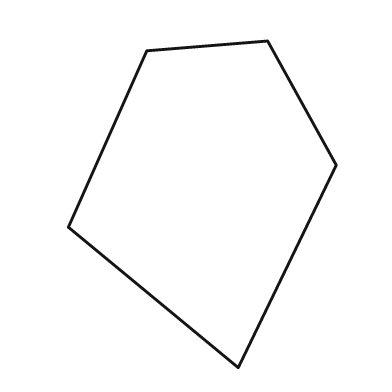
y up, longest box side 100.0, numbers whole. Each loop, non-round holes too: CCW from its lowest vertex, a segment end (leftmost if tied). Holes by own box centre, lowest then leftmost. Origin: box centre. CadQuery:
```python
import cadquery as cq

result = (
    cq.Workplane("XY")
    .moveTo(11.0, -50.0)
    .lineTo(41.0, 12.0)
    .lineTo(20.0, 50.0)
    .lineTo(-17.0, 47.0)
    .lineTo(-41.0, -7.0)
    .close()
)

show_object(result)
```